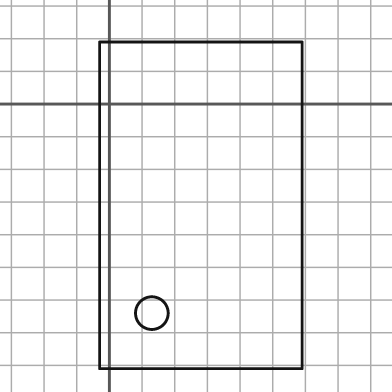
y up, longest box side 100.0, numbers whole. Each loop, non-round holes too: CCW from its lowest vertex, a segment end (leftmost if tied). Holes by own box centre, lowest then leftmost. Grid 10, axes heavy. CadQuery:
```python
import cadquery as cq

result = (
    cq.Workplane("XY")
    .moveTo(-3.0, -81.0)
    .lineTo(59.0, -81.0)
    .lineTo(59.0, 19.0)
    .lineTo(-3.0, 19.0)
    .close()
    .moveTo(13.0, -64.0)
    .circle(5.0)
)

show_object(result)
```